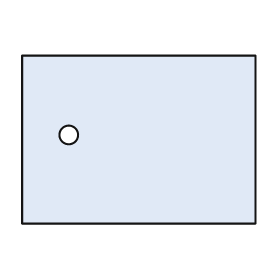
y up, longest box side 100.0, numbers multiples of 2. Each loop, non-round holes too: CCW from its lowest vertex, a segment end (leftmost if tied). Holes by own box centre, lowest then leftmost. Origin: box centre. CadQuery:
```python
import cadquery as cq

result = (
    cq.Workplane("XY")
    .moveTo(-50.0, -36.0)
    .lineTo(50.0, -36.0)
    .lineTo(50.0, 36.0)
    .lineTo(-50.0, 36.0)
    .close()
    .moveTo(-30.0, 2.0)
    .circle(4.0)
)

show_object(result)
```